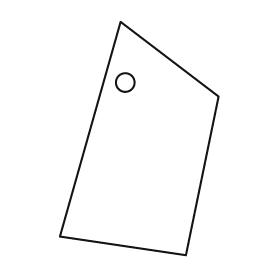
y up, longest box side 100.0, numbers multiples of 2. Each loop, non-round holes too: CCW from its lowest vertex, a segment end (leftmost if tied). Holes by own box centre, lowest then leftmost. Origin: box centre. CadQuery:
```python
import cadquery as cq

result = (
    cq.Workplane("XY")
    .moveTo(20.0, -50.0)
    .lineTo(34.0, 18.0)
    .lineTo(-8.0, 50.0)
    .lineTo(-34.0, -42.0)
    .close()
    .moveTo(-6.0, 24.0)
    .circle(4.0)
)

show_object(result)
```